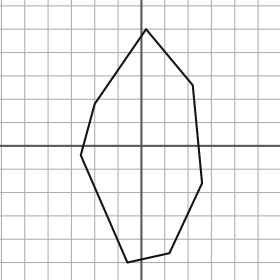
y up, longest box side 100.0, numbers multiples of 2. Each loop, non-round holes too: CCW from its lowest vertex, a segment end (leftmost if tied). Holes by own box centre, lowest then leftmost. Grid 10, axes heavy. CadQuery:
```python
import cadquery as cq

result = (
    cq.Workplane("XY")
    .moveTo(-6.0, -50.0)
    .lineTo(12.0, -46.0)
    .lineTo(26.0, -16.0)
    .lineTo(22.0, 26.0)
    .lineTo(2.0, 50.0)
    .lineTo(-20.0, 18.0)
    .lineTo(-26.0, -4.0)
    .close()
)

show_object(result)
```